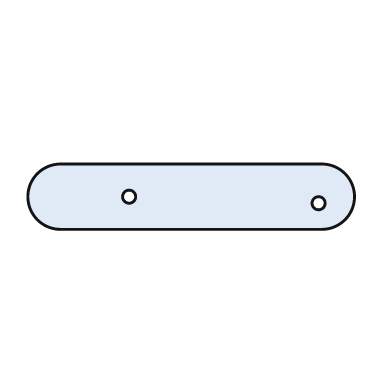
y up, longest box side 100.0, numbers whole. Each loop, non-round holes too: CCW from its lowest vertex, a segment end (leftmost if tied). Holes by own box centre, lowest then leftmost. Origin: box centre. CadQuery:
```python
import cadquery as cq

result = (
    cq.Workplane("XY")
    .moveTo(-40.0, -10.0)
    .lineTo(40.0, -10.0)
    .threePointArc((50.0, 0.0), (40.0, 10.0))
    .lineTo(-40.0, 10.0)
    .threePointArc((-50.0, 0.0), (-40.0, -10.0))
    .close()
    .moveTo(39.0, -2.0)
    .circle(2.0)
    .moveTo(-19.0, 0.0)
    .circle(2.0)
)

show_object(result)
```